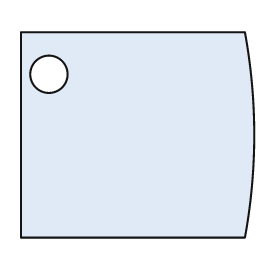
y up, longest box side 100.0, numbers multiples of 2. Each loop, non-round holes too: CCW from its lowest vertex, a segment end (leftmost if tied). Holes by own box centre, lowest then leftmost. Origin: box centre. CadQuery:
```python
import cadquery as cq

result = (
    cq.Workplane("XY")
    .moveTo(-50.0, -44.0)
    .lineTo(46.0, -44.0)
    .threePointArc((50.0, 0.0), (46.0, 44.0))
    .lineTo(-50.0, 44.0)
    .close()
    .moveTo(-38.0, 26.0)
    .circle(8.0)
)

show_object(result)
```